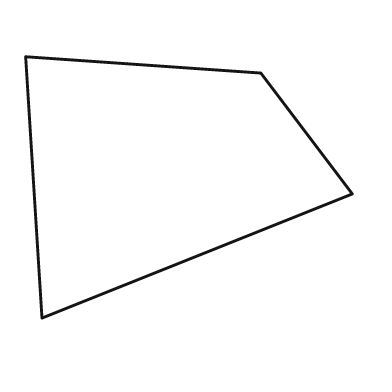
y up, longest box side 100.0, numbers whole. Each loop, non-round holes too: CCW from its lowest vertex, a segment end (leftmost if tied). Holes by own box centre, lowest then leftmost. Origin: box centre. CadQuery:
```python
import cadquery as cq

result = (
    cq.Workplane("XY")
    .moveTo(-45.0, -40.0)
    .lineTo(50.0, -2.0)
    .lineTo(22.0, 35.0)
    .lineTo(-50.0, 40.0)
    .close()
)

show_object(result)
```